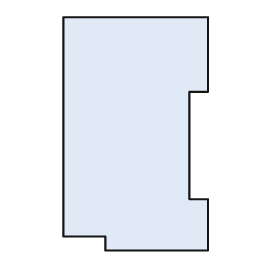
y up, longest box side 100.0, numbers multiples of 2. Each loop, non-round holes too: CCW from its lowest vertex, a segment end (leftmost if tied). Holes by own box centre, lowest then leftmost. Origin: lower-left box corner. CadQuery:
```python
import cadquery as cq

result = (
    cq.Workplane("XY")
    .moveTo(18.0, 0.0)
    .lineTo(62.0, 0.0)
    .lineTo(62.0, 22.0)
    .lineTo(54.0, 22.0)
    .lineTo(54.0, 68.0)
    .lineTo(62.0, 68.0)
    .lineTo(62.0, 100.0)
    .lineTo(0.0, 100.0)
    .lineTo(0.0, 6.0)
    .lineTo(18.0, 6.0)
    .close()
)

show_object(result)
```